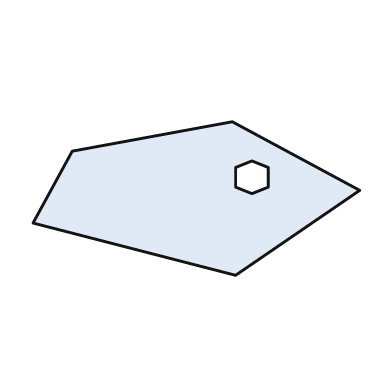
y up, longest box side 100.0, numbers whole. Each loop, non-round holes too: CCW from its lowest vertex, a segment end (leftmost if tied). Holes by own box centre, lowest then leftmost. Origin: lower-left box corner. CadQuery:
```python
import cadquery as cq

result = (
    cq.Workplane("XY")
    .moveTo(62.0, 0.0)
    .lineTo(100.0, 26.0)
    .lineTo(61.0, 47.0)
    .lineTo(12.0, 38.0)
    .lineTo(0.0, 16.0)
    .close()
    .moveTo(67.0, 25.0)
    .lineTo(72.0, 27.0)
    .lineTo(72.0, 33.0)
    .lineTo(67.0, 35.0)
    .lineTo(62.0, 33.0)
    .lineTo(62.0, 27.0)
    .close()
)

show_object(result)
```